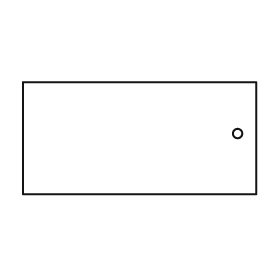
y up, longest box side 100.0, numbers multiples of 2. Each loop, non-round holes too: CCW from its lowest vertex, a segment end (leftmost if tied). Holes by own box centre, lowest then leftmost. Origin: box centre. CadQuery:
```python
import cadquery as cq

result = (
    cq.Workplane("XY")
    .moveTo(-50.0, -24.0)
    .lineTo(50.0, -24.0)
    .lineTo(50.0, 24.0)
    .lineTo(-50.0, 24.0)
    .close()
    .moveTo(42.0, 2.0)
    .circle(2.0)
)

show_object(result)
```